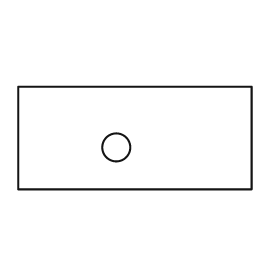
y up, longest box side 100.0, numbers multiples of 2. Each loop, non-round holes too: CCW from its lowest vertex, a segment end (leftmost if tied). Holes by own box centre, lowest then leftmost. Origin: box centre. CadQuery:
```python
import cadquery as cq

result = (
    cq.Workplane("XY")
    .moveTo(-50.0, -22.0)
    .lineTo(50.0, -22.0)
    .lineTo(50.0, 22.0)
    .lineTo(-50.0, 22.0)
    .close()
    .moveTo(-8.0, -4.0)
    .circle(6.0)
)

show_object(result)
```